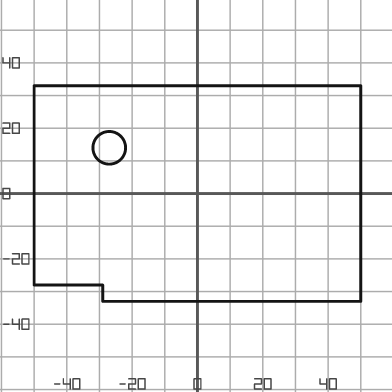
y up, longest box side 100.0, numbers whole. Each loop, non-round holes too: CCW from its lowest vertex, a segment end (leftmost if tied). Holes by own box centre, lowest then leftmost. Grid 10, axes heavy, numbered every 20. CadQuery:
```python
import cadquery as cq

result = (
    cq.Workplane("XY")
    .moveTo(-29.0, -33.0)
    .lineTo(50.0, -33.0)
    .lineTo(50.0, 33.0)
    .lineTo(-50.0, 33.0)
    .lineTo(-50.0, -28.0)
    .lineTo(-29.0, -28.0)
    .close()
    .moveTo(-27.0, 14.0)
    .circle(5.0)
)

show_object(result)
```